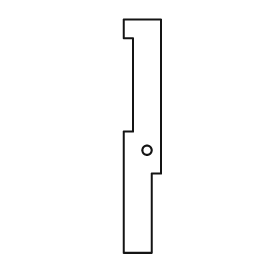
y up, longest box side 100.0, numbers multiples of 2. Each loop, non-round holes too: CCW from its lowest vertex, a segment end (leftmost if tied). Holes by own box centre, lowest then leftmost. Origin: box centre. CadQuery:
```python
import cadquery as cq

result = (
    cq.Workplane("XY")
    .moveTo(-8.0, -50.0)
    .lineTo(4.0, -50.0)
    .lineTo(4.0, -16.0)
    .lineTo(8.0, -16.0)
    .lineTo(8.0, 50.0)
    .lineTo(-8.0, 50.0)
    .lineTo(-8.0, 42.0)
    .lineTo(-4.0, 42.0)
    .lineTo(-4.0, 2.0)
    .lineTo(-8.0, 2.0)
    .close()
    .moveTo(2.0, -6.0)
    .circle(2.0)
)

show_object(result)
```